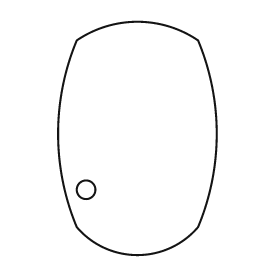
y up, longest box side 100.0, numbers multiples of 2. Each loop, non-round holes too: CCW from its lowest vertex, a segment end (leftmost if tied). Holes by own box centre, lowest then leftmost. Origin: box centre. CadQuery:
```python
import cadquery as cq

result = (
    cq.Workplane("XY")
    .moveTo(-26.0, -38.0)
    .threePointArc((0.0, -50.0), (26.0, -38.0))
    .threePointArc((34.0, 2.0), (26.0, 42.0))
    .threePointArc((0.0, 50.0), (-26.0, 42.0))
    .threePointArc((-34.0, 2.0), (-26.0, -38.0))
    .close()
    .moveTo(-22.0, -22.0)
    .circle(4.0)
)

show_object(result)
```